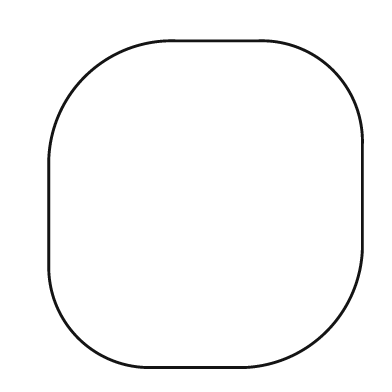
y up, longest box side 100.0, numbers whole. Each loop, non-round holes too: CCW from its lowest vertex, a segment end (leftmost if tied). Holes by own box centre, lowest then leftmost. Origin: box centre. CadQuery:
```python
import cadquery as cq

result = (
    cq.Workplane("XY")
    .moveTo(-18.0, -50.0)
    .lineTo(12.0, -50.0)
    .threePointArc((37.0, -39.0), (48.0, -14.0))
    .lineTo(48.0, 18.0)
    .threePointArc((39.0, 41.0), (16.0, 50.0))
    .lineTo(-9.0, 50.0)
    .threePointArc((-37.0, 39.0), (-48.0, 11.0))
    .lineTo(-48.0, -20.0)
    .threePointArc((-39.0, -41.0), (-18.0, -50.0))
    .close()
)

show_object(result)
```